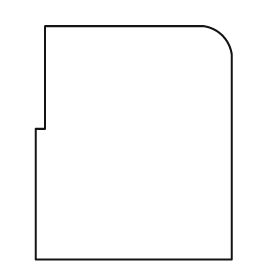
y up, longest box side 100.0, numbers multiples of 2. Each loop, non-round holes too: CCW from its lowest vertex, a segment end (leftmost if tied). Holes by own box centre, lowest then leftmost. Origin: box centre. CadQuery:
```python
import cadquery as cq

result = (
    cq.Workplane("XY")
    .moveTo(-42.0, -50.0)
    .lineTo(42.0, -50.0)
    .lineTo(42.0, 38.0)
    .threePointArc((38.0, 46.0), (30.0, 50.0))
    .lineTo(-38.0, 50.0)
    .lineTo(-38.0, 6.0)
    .lineTo(-42.0, 6.0)
    .close()
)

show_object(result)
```